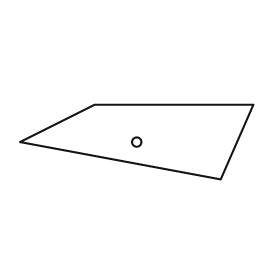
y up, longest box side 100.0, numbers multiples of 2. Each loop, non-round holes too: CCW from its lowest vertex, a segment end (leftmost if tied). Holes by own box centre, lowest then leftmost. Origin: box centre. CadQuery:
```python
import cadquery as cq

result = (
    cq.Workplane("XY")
    .moveTo(36.0, -16.0)
    .lineTo(50.0, 16.0)
    .lineTo(-18.0, 16.0)
    .lineTo(-50.0, 0.0)
    .close()
    .moveTo(0.0, 0.0)
    .circle(2.0)
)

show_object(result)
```